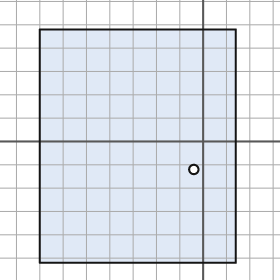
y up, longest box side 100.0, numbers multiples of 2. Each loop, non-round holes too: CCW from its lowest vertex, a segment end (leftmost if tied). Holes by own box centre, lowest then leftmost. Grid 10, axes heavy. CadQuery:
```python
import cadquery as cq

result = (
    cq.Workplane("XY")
    .moveTo(-70.0, -52.0)
    .lineTo(14.0, -52.0)
    .lineTo(14.0, 48.0)
    .lineTo(-70.0, 48.0)
    .close()
    .moveTo(-4.0, -12.0)
    .circle(2.0)
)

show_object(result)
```